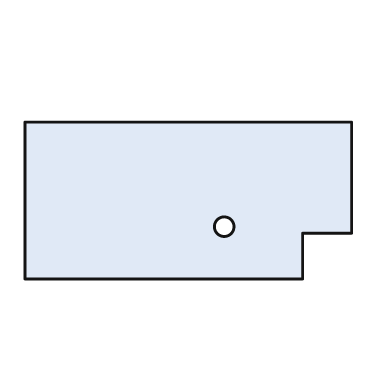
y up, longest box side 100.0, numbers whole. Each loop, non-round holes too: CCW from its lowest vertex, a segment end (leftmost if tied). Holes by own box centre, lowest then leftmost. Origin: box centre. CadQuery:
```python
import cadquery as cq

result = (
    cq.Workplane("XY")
    .moveTo(-50.0, -24.0)
    .lineTo(35.0, -24.0)
    .lineTo(35.0, -10.0)
    .lineTo(50.0, -10.0)
    .lineTo(50.0, 24.0)
    .lineTo(-50.0, 24.0)
    .close()
    .moveTo(11.0, -8.0)
    .circle(3.0)
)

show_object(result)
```